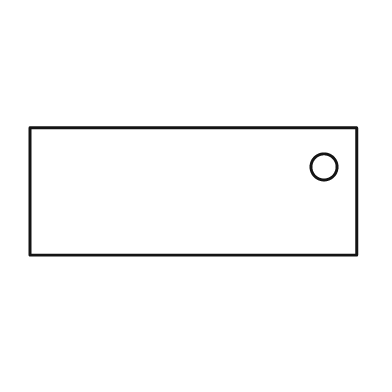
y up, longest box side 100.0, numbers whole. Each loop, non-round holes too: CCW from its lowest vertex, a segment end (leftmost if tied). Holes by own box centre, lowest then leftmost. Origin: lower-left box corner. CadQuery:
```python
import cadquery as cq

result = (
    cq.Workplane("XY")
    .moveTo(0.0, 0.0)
    .lineTo(100.0, 0.0)
    .lineTo(100.0, 39.0)
    .lineTo(0.0, 39.0)
    .close()
    .moveTo(90.0, 27.0)
    .circle(4.0)
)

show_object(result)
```